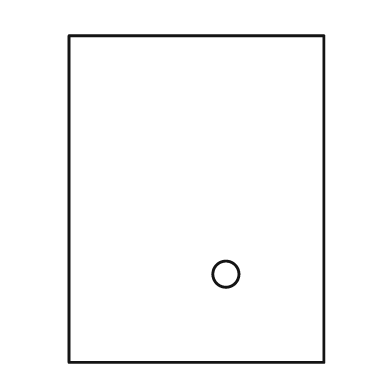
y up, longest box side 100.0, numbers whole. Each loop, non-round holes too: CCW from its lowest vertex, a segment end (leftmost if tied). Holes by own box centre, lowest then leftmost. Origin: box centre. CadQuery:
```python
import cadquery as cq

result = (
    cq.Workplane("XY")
    .moveTo(-39.0, -50.0)
    .lineTo(39.0, -50.0)
    .lineTo(39.0, 50.0)
    .lineTo(-39.0, 50.0)
    .close()
    .moveTo(9.0, -23.0)
    .circle(4.0)
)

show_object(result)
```